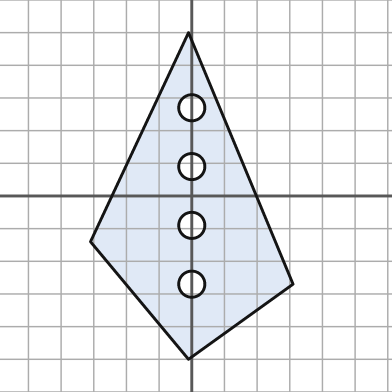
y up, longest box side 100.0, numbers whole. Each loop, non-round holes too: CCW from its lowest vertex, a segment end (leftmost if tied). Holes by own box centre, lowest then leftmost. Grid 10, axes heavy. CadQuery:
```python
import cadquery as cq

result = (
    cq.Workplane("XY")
    .moveTo(-1.0, -50.0)
    .lineTo(31.0, -27.0)
    .lineTo(-1.0, 50.0)
    .lineTo(-31.0, -14.0)
    .close()
    .moveTo(0.0, -27.0)
    .circle(4.0)
    .moveTo(0.0, -9.0)
    .circle(4.0)
    .moveTo(0.0, 9.0)
    .circle(4.0)
    .moveTo(0.0, 27.0)
    .circle(4.0)
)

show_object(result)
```